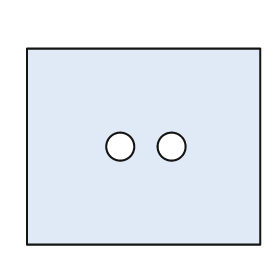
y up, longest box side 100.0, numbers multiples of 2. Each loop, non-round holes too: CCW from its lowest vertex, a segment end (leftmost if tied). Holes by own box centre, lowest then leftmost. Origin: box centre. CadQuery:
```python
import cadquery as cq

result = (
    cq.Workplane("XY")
    .moveTo(-50.0, -42.0)
    .lineTo(50.0, -42.0)
    .lineTo(50.0, 42.0)
    .lineTo(-50.0, 42.0)
    .close()
    .moveTo(-10.0, 0.0)
    .circle(6.0)
    .moveTo(12.0, 0.0)
    .circle(6.0)
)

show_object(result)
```